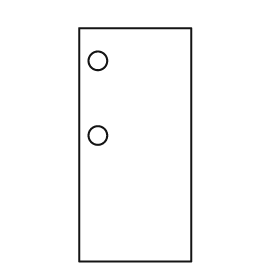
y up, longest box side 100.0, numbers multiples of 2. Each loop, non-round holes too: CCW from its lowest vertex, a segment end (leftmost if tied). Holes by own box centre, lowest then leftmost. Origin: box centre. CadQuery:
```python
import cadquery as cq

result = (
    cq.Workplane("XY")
    .moveTo(-24.0, -50.0)
    .lineTo(24.0, -50.0)
    .lineTo(24.0, 50.0)
    .lineTo(-24.0, 50.0)
    .close()
    .moveTo(-16.0, 4.0)
    .circle(4.0)
    .moveTo(-16.0, 36.0)
    .circle(4.0)
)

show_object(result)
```